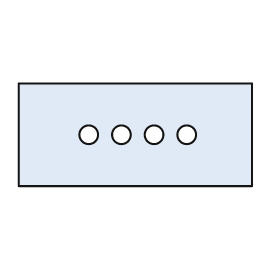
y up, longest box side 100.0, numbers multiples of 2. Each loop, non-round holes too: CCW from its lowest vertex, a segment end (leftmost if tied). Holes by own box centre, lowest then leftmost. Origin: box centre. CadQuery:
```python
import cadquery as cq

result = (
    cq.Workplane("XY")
    .moveTo(-50.0, -22.0)
    .lineTo(50.0, -22.0)
    .lineTo(50.0, 22.0)
    .lineTo(-50.0, 22.0)
    .close()
    .moveTo(-20.0, 0.0)
    .circle(4.0)
    .moveTo(-6.0, 0.0)
    .circle(4.0)
    .moveTo(8.0, 0.0)
    .circle(4.0)
    .moveTo(22.0, 0.0)
    .circle(4.0)
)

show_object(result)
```